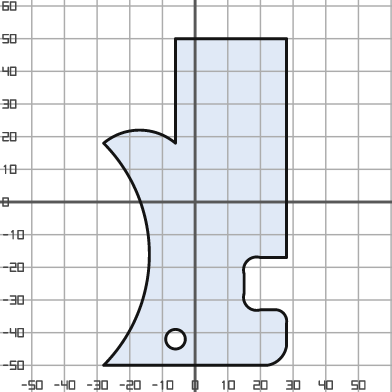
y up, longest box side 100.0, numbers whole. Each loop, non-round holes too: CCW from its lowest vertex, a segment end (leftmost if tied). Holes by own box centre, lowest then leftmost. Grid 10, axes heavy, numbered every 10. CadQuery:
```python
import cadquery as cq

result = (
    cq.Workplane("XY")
    .moveTo(-28.0, -50.0)
    .lineTo(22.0, -50.0)
    .threePointArc((26.0, -48.0), (28.0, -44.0))
    .lineTo(28.0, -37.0)
    .threePointArc((27.0, -34.0), (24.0, -33.0))
    .lineTo(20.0, -33.0)
    .threePointArc((16.0, -32.0), (15.0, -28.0))
    .lineTo(15.0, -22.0)
    .threePointArc((16.0, -18.0), (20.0, -17.0))
    .lineTo(28.0, -17.0)
    .lineTo(28.0, 50.0)
    .lineTo(-6.0, 50.0)
    .lineTo(-6.0, 18.0)
    .threePointArc((-17.0, 22.0), (-28.0, 18.0))
    .threePointArc((-14.0, -16.0), (-28.0, -50.0))
    .close()
    .moveTo(-6.0, -42.0)
    .circle(3.0)
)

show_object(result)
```